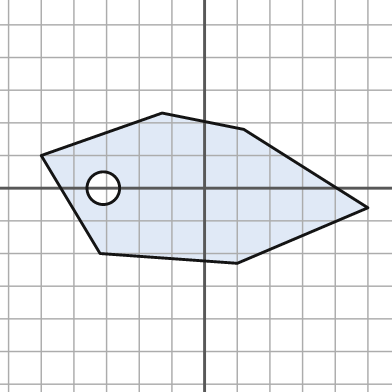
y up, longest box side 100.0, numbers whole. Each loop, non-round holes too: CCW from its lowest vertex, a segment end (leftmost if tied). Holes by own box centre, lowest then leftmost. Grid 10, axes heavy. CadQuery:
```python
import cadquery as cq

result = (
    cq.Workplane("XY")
    .moveTo(10.0, -23.0)
    .lineTo(50.0, -6.0)
    .lineTo(12.0, 18.0)
    .lineTo(-13.0, 23.0)
    .lineTo(-50.0, 10.0)
    .lineTo(-32.0, -20.0)
    .close()
    .moveTo(-31.0, 0.0)
    .circle(5.0)
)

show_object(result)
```